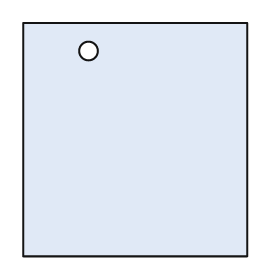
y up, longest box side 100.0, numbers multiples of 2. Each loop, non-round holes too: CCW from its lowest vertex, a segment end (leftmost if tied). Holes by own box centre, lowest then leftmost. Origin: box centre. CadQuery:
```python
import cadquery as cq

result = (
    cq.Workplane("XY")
    .moveTo(-48.0, -50.0)
    .lineTo(48.0, -50.0)
    .lineTo(48.0, 50.0)
    .lineTo(-48.0, 50.0)
    .close()
    .moveTo(-20.0, 38.0)
    .circle(4.0)
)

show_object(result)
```